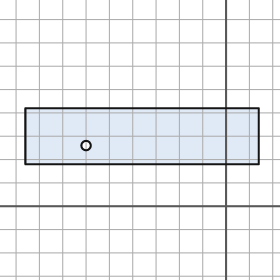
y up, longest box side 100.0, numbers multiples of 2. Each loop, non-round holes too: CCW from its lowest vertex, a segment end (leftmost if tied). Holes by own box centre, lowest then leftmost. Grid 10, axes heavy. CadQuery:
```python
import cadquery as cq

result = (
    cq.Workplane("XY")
    .moveTo(-86.0, 18.0)
    .lineTo(14.0, 18.0)
    .lineTo(14.0, 42.0)
    .lineTo(-86.0, 42.0)
    .close()
    .moveTo(-60.0, 26.0)
    .circle(2.0)
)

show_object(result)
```